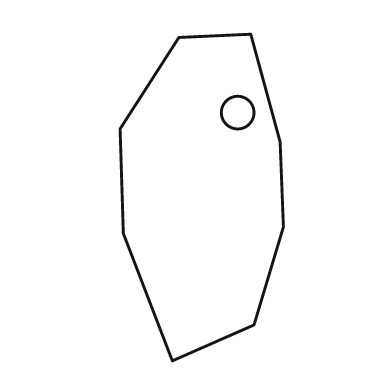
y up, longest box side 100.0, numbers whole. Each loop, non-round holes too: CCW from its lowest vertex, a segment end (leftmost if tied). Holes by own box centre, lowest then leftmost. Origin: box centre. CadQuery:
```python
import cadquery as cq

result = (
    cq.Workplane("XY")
    .moveTo(-9.0, -50.0)
    .lineTo(16.0, -39.0)
    .lineTo(25.0, -9.0)
    .lineTo(24.0, 17.0)
    .lineTo(15.0, 50.0)
    .lineTo(-7.0, 49.0)
    .lineTo(-25.0, 21.0)
    .lineTo(-24.0, -11.0)
    .close()
    .moveTo(11.0, 26.0)
    .circle(5.0)
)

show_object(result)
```